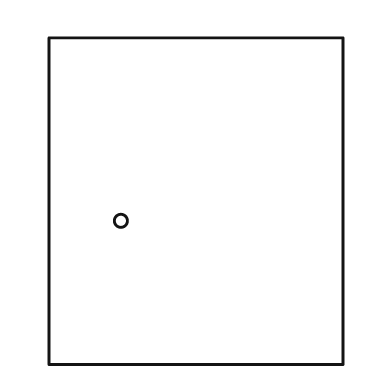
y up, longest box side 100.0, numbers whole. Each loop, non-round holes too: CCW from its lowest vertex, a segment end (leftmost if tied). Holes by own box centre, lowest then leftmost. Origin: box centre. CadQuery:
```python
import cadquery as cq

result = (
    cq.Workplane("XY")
    .moveTo(-45.0, -50.0)
    .lineTo(45.0, -50.0)
    .lineTo(45.0, 50.0)
    .lineTo(-45.0, 50.0)
    .close()
    .moveTo(-23.0, -6.0)
    .circle(2.0)
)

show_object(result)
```